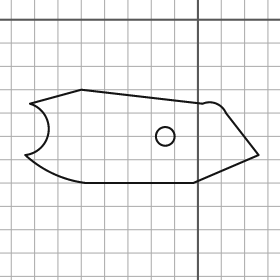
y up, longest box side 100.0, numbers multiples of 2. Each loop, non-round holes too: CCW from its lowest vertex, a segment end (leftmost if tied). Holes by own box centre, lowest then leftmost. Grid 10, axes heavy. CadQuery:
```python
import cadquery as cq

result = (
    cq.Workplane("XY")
    .moveTo(-48.0, -70.0)
    .lineTo(-2.0, -70.0)
    .lineTo(26.0, -58.0)
    .lineTo(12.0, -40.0)
    .threePointArc((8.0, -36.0), (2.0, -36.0))
    .lineTo(-50.0, -30.0)
    .lineTo(-72.0, -36.0)
    .threePointArc((-64.0, -48.0), (-74.0, -58.0))
    .threePointArc((-62.0, -66.0), (-48.0, -70.0))
    .close()
    .moveTo(-14.0, -50.0)
    .circle(4.0)
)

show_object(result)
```